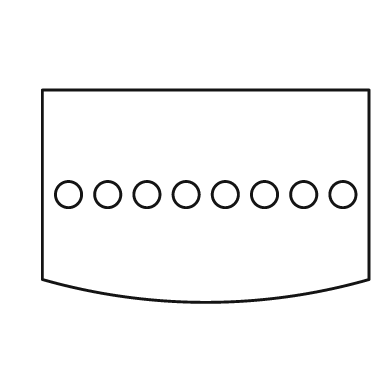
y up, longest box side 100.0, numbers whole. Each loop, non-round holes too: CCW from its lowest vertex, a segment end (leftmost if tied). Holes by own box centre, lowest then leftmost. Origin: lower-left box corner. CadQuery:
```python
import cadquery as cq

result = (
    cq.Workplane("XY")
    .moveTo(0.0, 7.0)
    .threePointArc((50.0, 0.0), (100.0, 7.0))
    .lineTo(100.0, 65.0)
    .lineTo(0.0, 65.0)
    .close()
    .moveTo(8.0, 33.0)
    .circle(4.0)
    .moveTo(20.0, 33.0)
    .circle(4.0)
    .moveTo(32.0, 33.0)
    .circle(4.0)
    .moveTo(44.0, 33.0)
    .circle(4.0)
    .moveTo(56.0, 33.0)
    .circle(4.0)
    .moveTo(68.0, 33.0)
    .circle(4.0)
    .moveTo(80.0, 33.0)
    .circle(4.0)
    .moveTo(92.0, 33.0)
    .circle(4.0)
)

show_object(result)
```